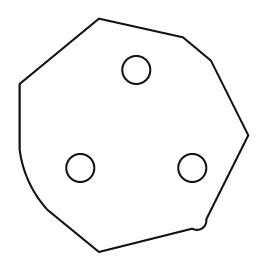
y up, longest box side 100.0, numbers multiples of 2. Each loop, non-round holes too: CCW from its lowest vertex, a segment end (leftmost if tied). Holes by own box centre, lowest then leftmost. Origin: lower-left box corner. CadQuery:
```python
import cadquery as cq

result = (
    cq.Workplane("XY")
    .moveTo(34.0, 0.0)
    .lineTo(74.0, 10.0)
    .threePointArc((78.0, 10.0), (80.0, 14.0))
    .lineTo(98.0, 50.0)
    .lineTo(82.0, 82.0)
    .lineTo(70.0, 92.0)
    .lineTo(34.0, 100.0)
    .lineTo(0.0, 72.0)
    .lineTo(0.0, 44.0)
    .threePointArc((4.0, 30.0), (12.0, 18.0))
    .close()
    .moveTo(26.0, 36.0)
    .circle(6.0)
    .moveTo(74.0, 36.0)
    .circle(6.0)
    .moveTo(50.0, 78.0)
    .circle(6.0)
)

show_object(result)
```